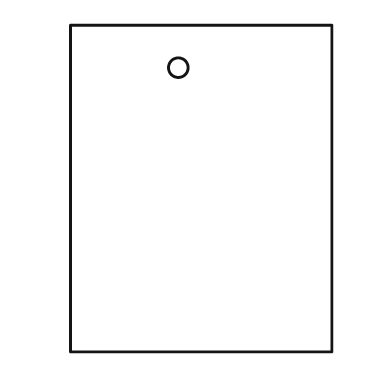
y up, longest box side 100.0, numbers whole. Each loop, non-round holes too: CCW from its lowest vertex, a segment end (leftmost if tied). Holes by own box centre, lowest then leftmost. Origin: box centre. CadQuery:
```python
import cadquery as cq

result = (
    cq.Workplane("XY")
    .moveTo(-40.0, -50.0)
    .lineTo(40.0, -50.0)
    .lineTo(40.0, 50.0)
    .lineTo(-40.0, 50.0)
    .close()
    .moveTo(-7.0, 37.0)
    .circle(3.0)
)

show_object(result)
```